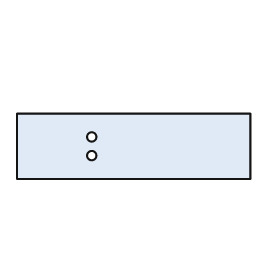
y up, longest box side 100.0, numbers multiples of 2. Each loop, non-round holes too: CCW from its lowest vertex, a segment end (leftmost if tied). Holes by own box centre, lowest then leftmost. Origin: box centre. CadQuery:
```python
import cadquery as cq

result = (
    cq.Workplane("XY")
    .moveTo(-50.0, -14.0)
    .lineTo(50.0, -14.0)
    .lineTo(50.0, 14.0)
    .lineTo(-50.0, 14.0)
    .close()
    .moveTo(-18.0, -4.0)
    .circle(2.0)
    .moveTo(-18.0, 4.0)
    .circle(2.0)
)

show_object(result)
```